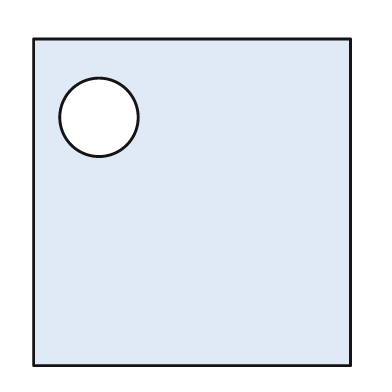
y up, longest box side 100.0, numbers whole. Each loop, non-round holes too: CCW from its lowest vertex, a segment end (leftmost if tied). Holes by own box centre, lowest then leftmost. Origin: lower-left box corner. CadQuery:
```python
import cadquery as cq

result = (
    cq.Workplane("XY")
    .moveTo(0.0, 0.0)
    .lineTo(97.0, 0.0)
    .lineTo(97.0, 100.0)
    .lineTo(0.0, 100.0)
    .close()
    .moveTo(20.0, 76.0)
    .circle(12.0)
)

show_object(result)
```